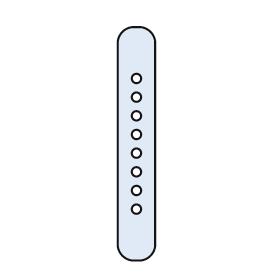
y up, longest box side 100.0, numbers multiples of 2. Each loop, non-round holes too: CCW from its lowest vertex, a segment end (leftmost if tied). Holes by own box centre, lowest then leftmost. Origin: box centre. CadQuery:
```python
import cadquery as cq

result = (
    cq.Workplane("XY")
    .moveTo(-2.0, -50.0)
    .lineTo(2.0, -50.0)
    .threePointArc((6.0, -48.0), (8.0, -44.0))
    .lineTo(8.0, 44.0)
    .threePointArc((6.0, 48.0), (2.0, 50.0))
    .lineTo(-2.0, 50.0)
    .threePointArc((-6.0, 48.0), (-8.0, 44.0))
    .lineTo(-8.0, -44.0)
    .threePointArc((-6.0, -48.0), (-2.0, -50.0))
    .close()
    .moveTo(0.0, -28.0)
    .circle(2.0)
    .moveTo(0.0, -20.0)
    .circle(2.0)
    .moveTo(0.0, -12.0)
    .circle(2.0)
    .moveTo(0.0, -4.0)
    .circle(2.0)
    .moveTo(0.0, 4.0)
    .circle(2.0)
    .moveTo(0.0, 12.0)
    .circle(2.0)
    .moveTo(0.0, 20.0)
    .circle(2.0)
    .moveTo(0.0, 28.0)
    .circle(2.0)
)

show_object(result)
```